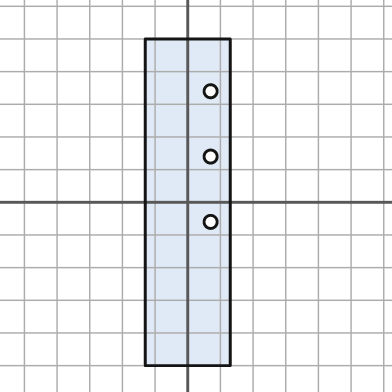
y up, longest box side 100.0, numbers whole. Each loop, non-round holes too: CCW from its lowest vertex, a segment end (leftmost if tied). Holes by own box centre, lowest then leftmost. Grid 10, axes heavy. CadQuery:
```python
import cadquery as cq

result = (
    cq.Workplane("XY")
    .moveTo(-13.0, -50.0)
    .lineTo(13.0, -50.0)
    .lineTo(13.0, 50.0)
    .lineTo(-13.0, 50.0)
    .close()
    .moveTo(7.0, -6.0)
    .circle(2.0)
    .moveTo(7.0, 14.0)
    .circle(2.0)
    .moveTo(7.0, 34.0)
    .circle(2.0)
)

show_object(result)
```